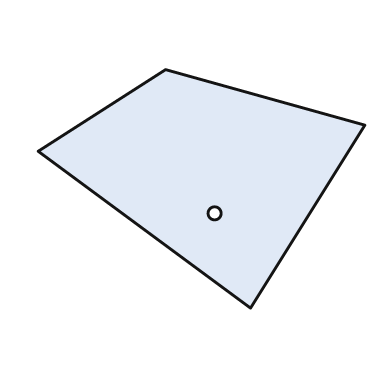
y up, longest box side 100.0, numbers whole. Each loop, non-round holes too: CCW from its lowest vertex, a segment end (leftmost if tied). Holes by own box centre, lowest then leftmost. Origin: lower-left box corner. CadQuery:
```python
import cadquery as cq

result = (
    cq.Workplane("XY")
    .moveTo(65.0, 0.0)
    .lineTo(100.0, 56.0)
    .lineTo(39.0, 73.0)
    .lineTo(0.0, 48.0)
    .close()
    .moveTo(54.0, 29.0)
    .circle(2.0)
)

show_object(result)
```